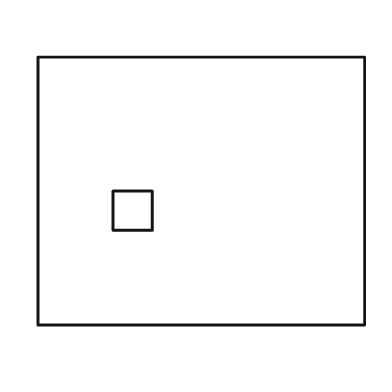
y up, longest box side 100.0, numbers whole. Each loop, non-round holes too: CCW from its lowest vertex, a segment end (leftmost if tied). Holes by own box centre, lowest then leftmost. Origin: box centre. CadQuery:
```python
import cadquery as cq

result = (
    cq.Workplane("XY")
    .moveTo(-50.0, -41.0)
    .lineTo(50.0, -41.0)
    .lineTo(50.0, 41.0)
    .lineTo(-50.0, 41.0)
    .close()
    .moveTo(-27.0, -12.0)
    .lineTo(-15.0, -12.0)
    .lineTo(-15.0, 0.0)
    .lineTo(-27.0, 0.0)
    .close()
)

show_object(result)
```